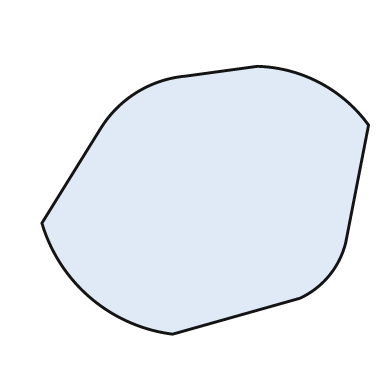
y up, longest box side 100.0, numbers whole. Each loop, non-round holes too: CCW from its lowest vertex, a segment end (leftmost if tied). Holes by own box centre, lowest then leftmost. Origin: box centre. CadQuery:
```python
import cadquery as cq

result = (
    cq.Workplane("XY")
    .moveTo(-10.0, -41.0)
    .lineTo(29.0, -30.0)
    .threePointArc((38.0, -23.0), (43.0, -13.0))
    .lineTo(50.0, 23.0)
    .threePointArc((35.0, 36.0), (16.0, 41.0))
    .lineTo(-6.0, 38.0)
    .threePointArc((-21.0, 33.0), (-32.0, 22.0))
    .lineTo(-50.0, -7.0)
    .threePointArc((-35.0, -30.0), (-10.0, -41.0))
    .close()
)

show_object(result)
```